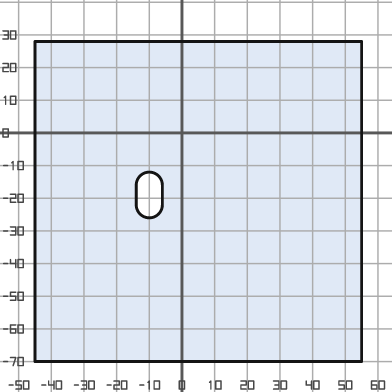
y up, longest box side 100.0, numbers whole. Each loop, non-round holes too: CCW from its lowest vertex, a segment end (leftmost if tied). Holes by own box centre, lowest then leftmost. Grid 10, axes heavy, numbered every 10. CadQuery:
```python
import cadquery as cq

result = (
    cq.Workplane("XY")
    .moveTo(-45.0, -70.0)
    .lineTo(55.0, -70.0)
    .lineTo(55.0, 28.0)
    .lineTo(-45.0, 28.0)
    .close()
    .moveTo(-14.0, -22.0)
    .threePointArc((-10.0, -26.0), (-6.0, -22.0))
    .lineTo(-6.0, -16.0)
    .threePointArc((-10.0, -12.0), (-14.0, -16.0))
    .close()
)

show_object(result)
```